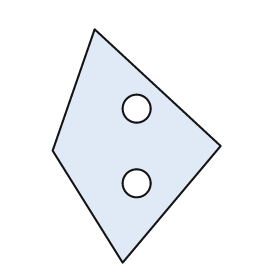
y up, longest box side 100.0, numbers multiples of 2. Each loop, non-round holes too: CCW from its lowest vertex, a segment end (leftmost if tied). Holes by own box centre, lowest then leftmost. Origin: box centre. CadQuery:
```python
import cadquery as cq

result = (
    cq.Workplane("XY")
    .moveTo(-6.0, -50.0)
    .lineTo(36.0, 0.0)
    .lineTo(-18.0, 50.0)
    .lineTo(-36.0, -2.0)
    .close()
    .moveTo(0.0, -16.0)
    .circle(6.0)
    .moveTo(0.0, 16.0)
    .circle(6.0)
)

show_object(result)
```